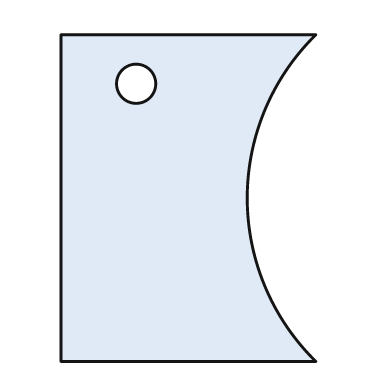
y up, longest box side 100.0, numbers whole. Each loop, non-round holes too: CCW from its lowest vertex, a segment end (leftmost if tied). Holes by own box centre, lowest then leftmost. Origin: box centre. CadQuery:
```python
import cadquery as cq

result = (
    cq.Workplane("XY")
    .moveTo(-39.0, -50.0)
    .lineTo(39.0, -50.0)
    .threePointArc((18.0, 0.0), (39.0, 50.0))
    .lineTo(-39.0, 50.0)
    .close()
    .moveTo(-16.0, 35.0)
    .circle(6.0)
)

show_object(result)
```